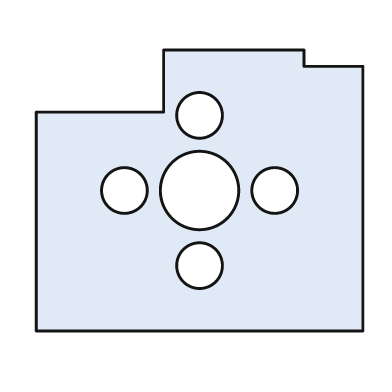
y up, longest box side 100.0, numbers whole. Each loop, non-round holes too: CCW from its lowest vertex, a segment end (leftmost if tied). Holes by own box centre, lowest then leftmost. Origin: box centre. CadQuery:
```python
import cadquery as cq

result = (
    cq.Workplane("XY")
    .moveTo(-50.0, -43.0)
    .lineTo(50.0, -43.0)
    .lineTo(50.0, 38.0)
    .lineTo(32.0, 38.0)
    .lineTo(32.0, 43.0)
    .lineTo(-11.0, 43.0)
    .lineTo(-11.0, 24.0)
    .lineTo(-50.0, 24.0)
    .close()
    .moveTo(0.0, -23.0)
    .circle(7.0)
    .moveTo(-23.0, 0.0)
    .circle(7.0)
    .moveTo(0.0, 0.0)
    .circle(12.0)
    .moveTo(23.0, 0.0)
    .circle(7.0)
    .moveTo(0.0, 23.0)
    .circle(7.0)
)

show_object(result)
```